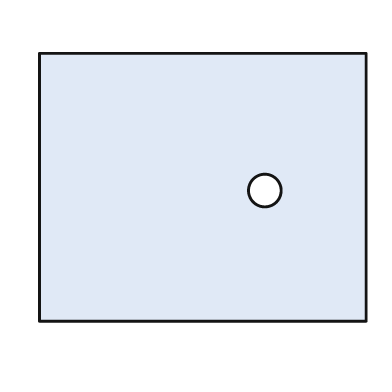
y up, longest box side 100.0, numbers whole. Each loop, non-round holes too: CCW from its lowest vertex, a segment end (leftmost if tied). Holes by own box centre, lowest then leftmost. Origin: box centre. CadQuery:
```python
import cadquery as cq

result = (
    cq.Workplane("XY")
    .moveTo(-50.0, -41.0)
    .lineTo(50.0, -41.0)
    .lineTo(50.0, 41.0)
    .lineTo(-50.0, 41.0)
    .close()
    .moveTo(19.0, -1.0)
    .circle(5.0)
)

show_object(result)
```